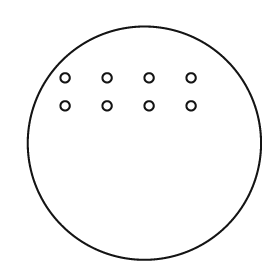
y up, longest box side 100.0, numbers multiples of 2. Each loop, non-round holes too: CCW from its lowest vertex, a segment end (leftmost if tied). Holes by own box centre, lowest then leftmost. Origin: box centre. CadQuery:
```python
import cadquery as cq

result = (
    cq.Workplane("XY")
    .moveTo(0.0, 0.0)
    .circle(50.0)
    .moveTo(-34.0, 16.0)
    .circle(2.0)
    .moveTo(-16.0, 16.0)
    .circle(2.0)
    .moveTo(2.0, 16.0)
    .circle(2.0)
    .moveTo(20.0, 16.0)
    .circle(2.0)
    .moveTo(-34.0, 28.0)
    .circle(2.0)
    .moveTo(-16.0, 28.0)
    .circle(2.0)
    .moveTo(2.0, 28.0)
    .circle(2.0)
    .moveTo(20.0, 28.0)
    .circle(2.0)
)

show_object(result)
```